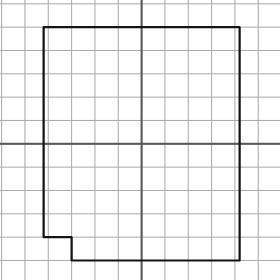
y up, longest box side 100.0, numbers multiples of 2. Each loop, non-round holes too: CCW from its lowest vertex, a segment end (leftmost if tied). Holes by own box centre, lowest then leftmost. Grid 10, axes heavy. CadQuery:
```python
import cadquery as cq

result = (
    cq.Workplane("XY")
    .moveTo(-30.0, -50.0)
    .lineTo(42.0, -50.0)
    .lineTo(42.0, 50.0)
    .lineTo(-42.0, 50.0)
    .lineTo(-42.0, -40.0)
    .lineTo(-30.0, -40.0)
    .close()
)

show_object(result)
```